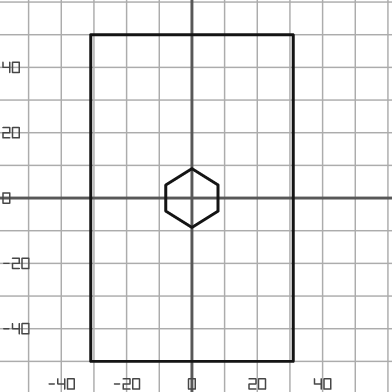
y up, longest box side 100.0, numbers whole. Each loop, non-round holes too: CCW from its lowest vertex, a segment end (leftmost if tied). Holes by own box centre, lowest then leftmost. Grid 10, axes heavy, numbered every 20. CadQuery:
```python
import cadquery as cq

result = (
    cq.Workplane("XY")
    .moveTo(-31.0, -50.0)
    .lineTo(31.0, -50.0)
    .lineTo(31.0, 50.0)
    .lineTo(-31.0, 50.0)
    .close()
    .moveTo(0.0, -9.0)
    .lineTo(8.0, -4.0)
    .lineTo(8.0, 4.0)
    .lineTo(0.0, 9.0)
    .lineTo(-8.0, 4.0)
    .lineTo(-8.0, -4.0)
    .close()
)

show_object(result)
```